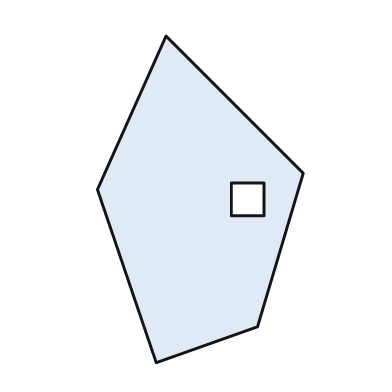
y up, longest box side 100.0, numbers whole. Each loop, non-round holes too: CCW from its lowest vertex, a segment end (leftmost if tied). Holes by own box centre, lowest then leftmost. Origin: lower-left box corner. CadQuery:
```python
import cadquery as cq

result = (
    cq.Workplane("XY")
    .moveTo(18.0, 0.0)
    .lineTo(49.0, 11.0)
    .lineTo(63.0, 58.0)
    .lineTo(21.0, 100.0)
    .lineTo(0.0, 53.0)
    .close()
    .moveTo(41.0, 45.0)
    .lineTo(51.0, 45.0)
    .lineTo(51.0, 55.0)
    .lineTo(41.0, 55.0)
    .close()
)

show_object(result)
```